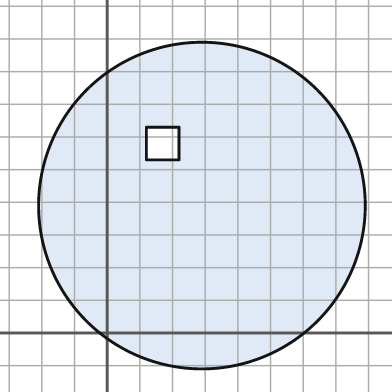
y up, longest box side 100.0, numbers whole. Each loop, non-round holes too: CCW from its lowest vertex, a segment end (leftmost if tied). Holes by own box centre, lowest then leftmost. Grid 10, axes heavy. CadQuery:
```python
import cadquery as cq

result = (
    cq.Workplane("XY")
    .moveTo(29.0, 39.0)
    .circle(50.0)
    .moveTo(12.0, 53.0)
    .lineTo(22.0, 53.0)
    .lineTo(22.0, 63.0)
    .lineTo(12.0, 63.0)
    .close()
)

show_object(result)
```